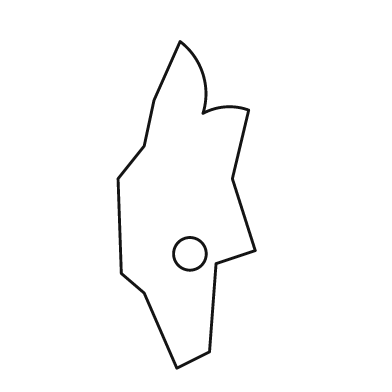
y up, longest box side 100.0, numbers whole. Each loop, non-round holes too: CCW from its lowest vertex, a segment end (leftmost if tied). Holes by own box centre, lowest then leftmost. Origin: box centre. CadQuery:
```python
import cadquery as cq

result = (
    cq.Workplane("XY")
    .moveTo(-3.0, -50.0)
    .lineTo(7.0, -45.0)
    .lineTo(9.0, -18.0)
    .lineTo(21.0, -14.0)
    .lineTo(14.0, 8.0)
    .lineTo(19.0, 29.0)
    .threePointArc((12.0, 30.0), (5.0, 28.0))
    .threePointArc((5.0, 40.0), (-2.0, 50.0))
    .lineTo(-10.0, 32.0)
    .lineTo(-13.0, 18.0)
    .lineTo(-21.0, 8.0)
    .lineTo(-20.0, -21.0)
    .lineTo(-13.0, -27.0)
    .close()
    .moveTo(1.0, -15.0)
    .circle(5.0)
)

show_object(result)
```